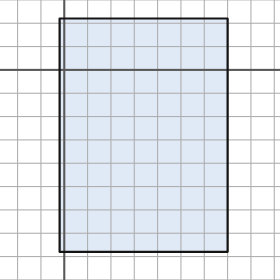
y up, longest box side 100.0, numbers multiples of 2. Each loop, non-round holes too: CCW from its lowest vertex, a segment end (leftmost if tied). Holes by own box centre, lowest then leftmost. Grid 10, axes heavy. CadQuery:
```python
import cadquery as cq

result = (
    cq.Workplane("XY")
    .moveTo(-2.0, -78.0)
    .lineTo(70.0, -78.0)
    .lineTo(70.0, 22.0)
    .lineTo(-2.0, 22.0)
    .close()
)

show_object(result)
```